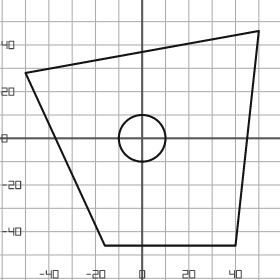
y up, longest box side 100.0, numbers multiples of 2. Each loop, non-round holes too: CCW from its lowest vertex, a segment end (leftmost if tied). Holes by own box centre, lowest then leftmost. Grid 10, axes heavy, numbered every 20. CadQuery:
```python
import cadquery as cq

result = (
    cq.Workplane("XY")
    .moveTo(-16.0, -46.0)
    .lineTo(40.0, -46.0)
    .lineTo(50.0, 46.0)
    .lineTo(-50.0, 28.0)
    .close()
    .moveTo(0.0, 0.0)
    .circle(10.0)
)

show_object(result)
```